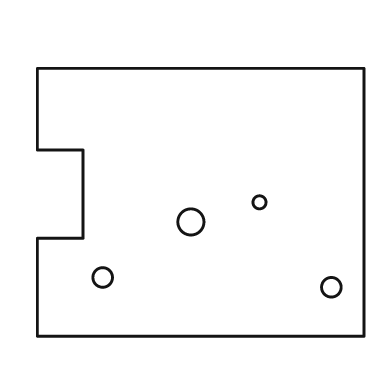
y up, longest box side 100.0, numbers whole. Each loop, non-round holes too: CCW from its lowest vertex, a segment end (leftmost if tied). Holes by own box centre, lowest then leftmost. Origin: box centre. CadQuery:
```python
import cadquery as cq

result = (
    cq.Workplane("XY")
    .moveTo(-50.0, -41.0)
    .lineTo(50.0, -41.0)
    .lineTo(50.0, 41.0)
    .lineTo(-50.0, 41.0)
    .lineTo(-50.0, 16.0)
    .lineTo(-36.0, 16.0)
    .lineTo(-36.0, -11.0)
    .lineTo(-50.0, -11.0)
    .close()
    .moveTo(40.0, -26.0)
    .circle(3.0)
    .moveTo(-30.0, -23.0)
    .circle(3.0)
    .moveTo(-3.0, -6.0)
    .circle(4.0)
    .moveTo(18.0, 0.0)
    .circle(2.0)
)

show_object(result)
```